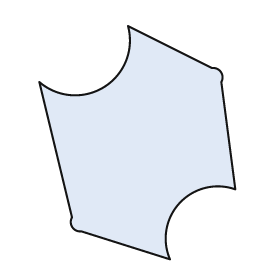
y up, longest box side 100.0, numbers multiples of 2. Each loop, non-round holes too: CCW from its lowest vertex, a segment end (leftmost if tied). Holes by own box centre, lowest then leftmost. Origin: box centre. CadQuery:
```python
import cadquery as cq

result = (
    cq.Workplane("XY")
    .moveTo(14.0, -50.0)
    .threePointArc((18.0, -26.0), (42.0, -20.0))
    .lineTo(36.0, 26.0)
    .threePointArc((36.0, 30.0), (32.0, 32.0))
    .lineTo(-4.0, 50.0)
    .threePointArc((-14.0, 24.0), (-42.0, 26.0))
    .lineTo(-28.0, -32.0)
    .threePointArc((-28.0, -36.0), (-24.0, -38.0))
    .close()
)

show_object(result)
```